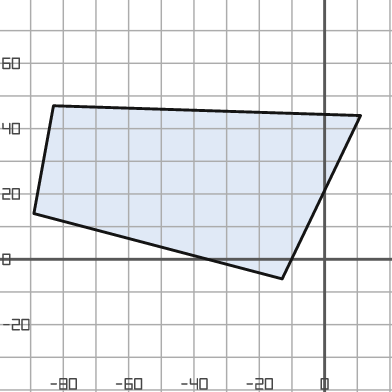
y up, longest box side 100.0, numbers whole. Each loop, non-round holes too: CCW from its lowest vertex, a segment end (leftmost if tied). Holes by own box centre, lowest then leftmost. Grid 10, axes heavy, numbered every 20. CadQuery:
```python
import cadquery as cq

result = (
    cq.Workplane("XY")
    .moveTo(-13.0, -6.0)
    .lineTo(11.0, 44.0)
    .lineTo(-83.0, 47.0)
    .lineTo(-89.0, 14.0)
    .close()
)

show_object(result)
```